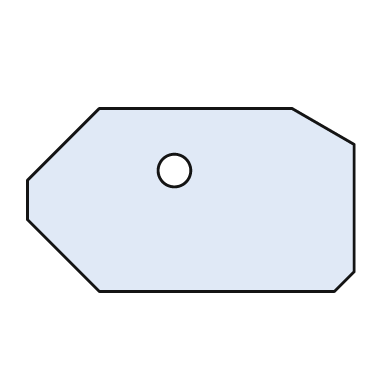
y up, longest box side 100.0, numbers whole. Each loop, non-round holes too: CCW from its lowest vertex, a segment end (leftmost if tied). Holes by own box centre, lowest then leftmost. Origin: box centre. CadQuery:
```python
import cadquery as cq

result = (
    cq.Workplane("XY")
    .moveTo(-28.0, -28.0)
    .lineTo(44.0, -28.0)
    .lineTo(50.0, -22.0)
    .lineTo(50.0, 17.0)
    .lineTo(31.0, 28.0)
    .lineTo(-28.0, 28.0)
    .lineTo(-50.0, 6.0)
    .lineTo(-50.0, -6.0)
    .close()
    .moveTo(-5.0, 9.0)
    .circle(5.0)
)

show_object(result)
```